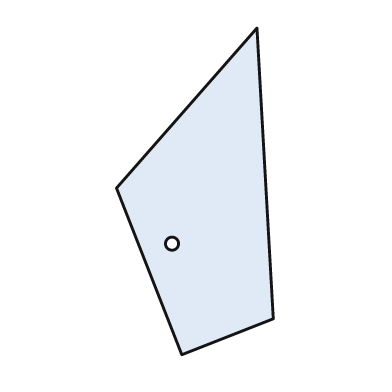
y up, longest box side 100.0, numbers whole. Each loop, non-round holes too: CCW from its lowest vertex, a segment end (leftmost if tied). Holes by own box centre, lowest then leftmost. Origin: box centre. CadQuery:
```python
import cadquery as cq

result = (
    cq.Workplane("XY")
    .moveTo(-4.0, -50.0)
    .lineTo(24.0, -39.0)
    .lineTo(19.0, 50.0)
    .lineTo(-24.0, 1.0)
    .close()
    .moveTo(-7.0, -16.0)
    .circle(2.0)
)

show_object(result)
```